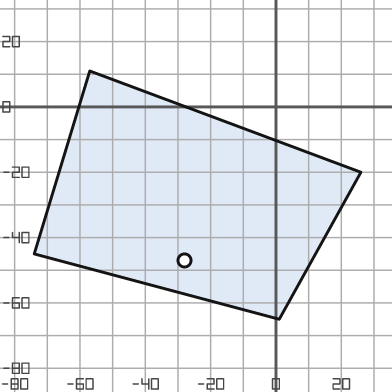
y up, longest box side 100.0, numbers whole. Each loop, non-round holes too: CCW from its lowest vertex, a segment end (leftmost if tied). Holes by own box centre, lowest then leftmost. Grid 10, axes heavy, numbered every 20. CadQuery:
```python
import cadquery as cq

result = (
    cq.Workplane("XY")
    .moveTo(1.0, -65.0)
    .lineTo(26.0, -20.0)
    .lineTo(-57.0, 11.0)
    .lineTo(-74.0, -45.0)
    .close()
    .moveTo(-28.0, -47.0)
    .circle(2.0)
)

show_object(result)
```